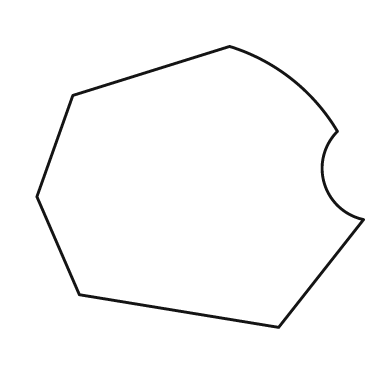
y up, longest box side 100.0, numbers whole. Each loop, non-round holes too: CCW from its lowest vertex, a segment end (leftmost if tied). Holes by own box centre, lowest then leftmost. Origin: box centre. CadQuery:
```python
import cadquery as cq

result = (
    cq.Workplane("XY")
    .moveTo(24.0, -43.0)
    .lineTo(50.0, -10.0)
    .threePointArc((38.0, 1.0), (42.0, 17.0))
    .threePointArc((28.0, 33.0), (9.0, 43.0))
    .lineTo(-39.0, 28.0)
    .lineTo(-50.0, -3.0)
    .lineTo(-37.0, -33.0)
    .close()
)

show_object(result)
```